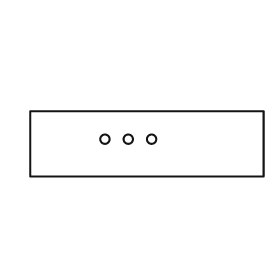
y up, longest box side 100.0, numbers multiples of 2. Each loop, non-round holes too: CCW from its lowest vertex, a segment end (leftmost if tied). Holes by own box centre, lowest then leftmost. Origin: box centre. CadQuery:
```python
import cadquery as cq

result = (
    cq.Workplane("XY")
    .moveTo(-50.0, -14.0)
    .lineTo(50.0, -14.0)
    .lineTo(50.0, 14.0)
    .lineTo(-50.0, 14.0)
    .close()
    .moveTo(-18.0, 2.0)
    .circle(2.0)
    .moveTo(-8.0, 2.0)
    .circle(2.0)
    .moveTo(2.0, 2.0)
    .circle(2.0)
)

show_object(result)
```